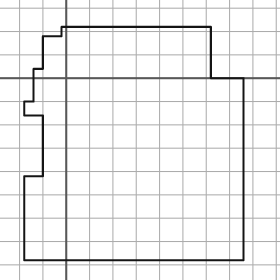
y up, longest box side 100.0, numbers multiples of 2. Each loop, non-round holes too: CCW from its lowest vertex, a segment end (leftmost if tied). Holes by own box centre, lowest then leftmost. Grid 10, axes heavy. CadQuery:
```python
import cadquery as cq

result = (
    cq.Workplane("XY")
    .moveTo(-18.0, -78.0)
    .lineTo(76.0, -78.0)
    .lineTo(76.0, 0.0)
    .lineTo(62.0, 0.0)
    .lineTo(62.0, 22.0)
    .lineTo(-2.0, 22.0)
    .lineTo(-2.0, 18.0)
    .lineTo(-10.0, 18.0)
    .lineTo(-10.0, 4.0)
    .lineTo(-14.0, 4.0)
    .lineTo(-14.0, -10.0)
    .lineTo(-18.0, -10.0)
    .lineTo(-18.0, -16.0)
    .lineTo(-10.0, -16.0)
    .lineTo(-10.0, -42.0)
    .lineTo(-18.0, -42.0)
    .close()
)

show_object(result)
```